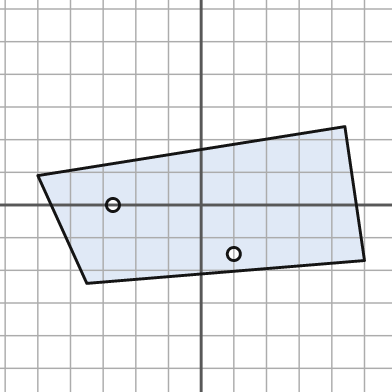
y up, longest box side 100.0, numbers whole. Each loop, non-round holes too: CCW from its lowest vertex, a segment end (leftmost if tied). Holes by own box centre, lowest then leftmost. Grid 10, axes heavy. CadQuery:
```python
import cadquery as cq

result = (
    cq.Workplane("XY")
    .moveTo(-35.0, -24.0)
    .lineTo(50.0, -17.0)
    .lineTo(44.0, 24.0)
    .lineTo(-50.0, 9.0)
    .close()
    .moveTo(10.0, -15.0)
    .circle(2.0)
    .moveTo(-27.0, 0.0)
    .circle(2.0)
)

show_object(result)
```